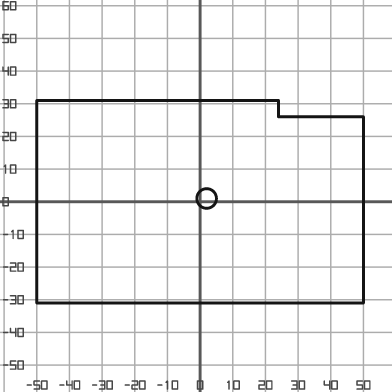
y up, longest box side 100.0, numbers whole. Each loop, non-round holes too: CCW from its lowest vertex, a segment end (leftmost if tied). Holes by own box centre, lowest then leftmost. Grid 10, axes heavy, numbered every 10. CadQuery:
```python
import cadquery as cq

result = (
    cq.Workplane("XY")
    .moveTo(-50.0, -31.0)
    .lineTo(50.0, -31.0)
    .lineTo(50.0, 26.0)
    .lineTo(24.0, 26.0)
    .lineTo(24.0, 31.0)
    .lineTo(-50.0, 31.0)
    .close()
    .moveTo(2.0, 1.0)
    .circle(3.0)
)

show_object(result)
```